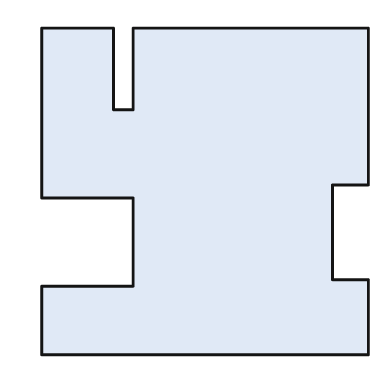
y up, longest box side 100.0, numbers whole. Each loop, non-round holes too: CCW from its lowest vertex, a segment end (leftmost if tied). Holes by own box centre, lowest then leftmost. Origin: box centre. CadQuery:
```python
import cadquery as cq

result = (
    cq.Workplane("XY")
    .moveTo(-50.0, -50.0)
    .lineTo(50.0, -50.0)
    .lineTo(50.0, -27.0)
    .lineTo(39.0, -27.0)
    .lineTo(39.0, 2.0)
    .lineTo(50.0, 2.0)
    .lineTo(50.0, 50.0)
    .lineTo(-22.0, 50.0)
    .lineTo(-22.0, 25.0)
    .lineTo(-28.0, 25.0)
    .lineTo(-28.0, 50.0)
    .lineTo(-50.0, 50.0)
    .lineTo(-50.0, -2.0)
    .lineTo(-22.0, -2.0)
    .lineTo(-22.0, -29.0)
    .lineTo(-50.0, -29.0)
    .close()
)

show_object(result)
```